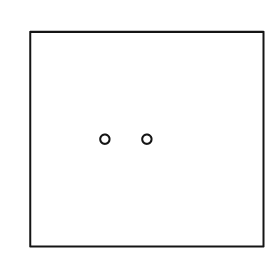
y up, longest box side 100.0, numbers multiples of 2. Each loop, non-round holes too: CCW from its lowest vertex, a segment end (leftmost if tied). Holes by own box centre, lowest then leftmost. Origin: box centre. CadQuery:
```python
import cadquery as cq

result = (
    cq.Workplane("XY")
    .moveTo(-50.0, -46.0)
    .lineTo(50.0, -46.0)
    .lineTo(50.0, 46.0)
    .lineTo(-50.0, 46.0)
    .close()
    .moveTo(-18.0, 0.0)
    .circle(2.0)
    .moveTo(0.0, 0.0)
    .circle(2.0)
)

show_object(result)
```